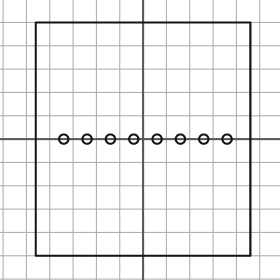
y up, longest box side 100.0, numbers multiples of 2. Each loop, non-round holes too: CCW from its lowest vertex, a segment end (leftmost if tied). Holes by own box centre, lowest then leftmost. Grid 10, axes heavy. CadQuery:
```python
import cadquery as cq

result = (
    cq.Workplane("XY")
    .moveTo(-46.0, -50.0)
    .lineTo(46.0, -50.0)
    .lineTo(46.0, 50.0)
    .lineTo(-46.0, 50.0)
    .close()
    .moveTo(-34.0, 0.0)
    .circle(2.0)
    .moveTo(-24.0, 0.0)
    .circle(2.0)
    .moveTo(-14.0, 0.0)
    .circle(2.0)
    .moveTo(-4.0, 0.0)
    .circle(2.0)
    .moveTo(6.0, 0.0)
    .circle(2.0)
    .moveTo(16.0, 0.0)
    .circle(2.0)
    .moveTo(26.0, 0.0)
    .circle(2.0)
    .moveTo(36.0, 0.0)
    .circle(2.0)
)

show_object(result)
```